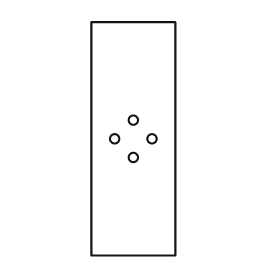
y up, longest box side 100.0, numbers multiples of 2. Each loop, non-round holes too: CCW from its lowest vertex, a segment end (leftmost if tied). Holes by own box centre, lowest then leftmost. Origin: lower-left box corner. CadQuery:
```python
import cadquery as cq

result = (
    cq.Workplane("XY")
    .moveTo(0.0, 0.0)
    .lineTo(36.0, 0.0)
    .lineTo(36.0, 100.0)
    .lineTo(0.0, 100.0)
    .close()
    .moveTo(18.0, 42.0)
    .circle(2.0)
    .moveTo(10.0, 50.0)
    .circle(2.0)
    .moveTo(26.0, 50.0)
    .circle(2.0)
    .moveTo(18.0, 58.0)
    .circle(2.0)
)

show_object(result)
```